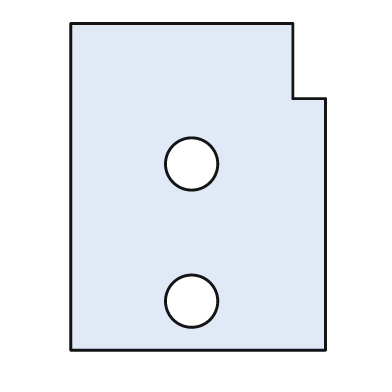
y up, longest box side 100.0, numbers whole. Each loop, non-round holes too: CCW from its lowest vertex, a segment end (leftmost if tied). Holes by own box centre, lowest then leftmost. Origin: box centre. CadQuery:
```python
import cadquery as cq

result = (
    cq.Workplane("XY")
    .moveTo(-39.0, -50.0)
    .lineTo(39.0, -50.0)
    .lineTo(39.0, 27.0)
    .lineTo(29.0, 27.0)
    .lineTo(29.0, 50.0)
    .lineTo(-39.0, 50.0)
    .close()
    .moveTo(-2.0, -35.0)
    .circle(8.0)
    .moveTo(-2.0, 7.0)
    .circle(8.0)
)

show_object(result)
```